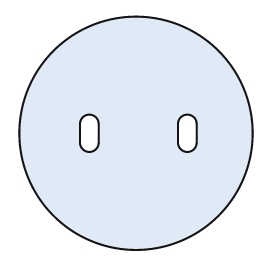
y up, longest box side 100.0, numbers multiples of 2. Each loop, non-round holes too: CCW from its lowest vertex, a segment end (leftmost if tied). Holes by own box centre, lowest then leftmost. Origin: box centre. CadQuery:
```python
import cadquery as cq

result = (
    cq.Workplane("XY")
    .moveTo(0.0, 0.0)
    .circle(50.0)
    .moveTo(-24.0, -4.0)
    .threePointArc((-20.0, -8.0), (-16.0, -4.0))
    .lineTo(-16.0, 4.0)
    .threePointArc((-20.0, 8.0), (-24.0, 4.0))
    .close()
    .moveTo(18.0, -4.0)
    .threePointArc((22.0, -8.0), (26.0, -4.0))
    .lineTo(26.0, 4.0)
    .threePointArc((22.0, 8.0), (18.0, 4.0))
    .close()
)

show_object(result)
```